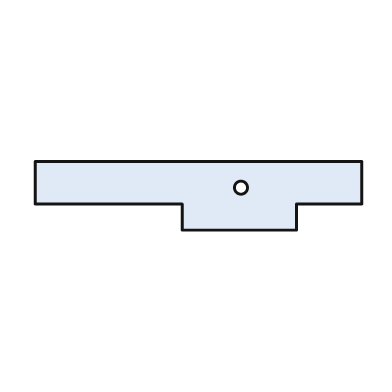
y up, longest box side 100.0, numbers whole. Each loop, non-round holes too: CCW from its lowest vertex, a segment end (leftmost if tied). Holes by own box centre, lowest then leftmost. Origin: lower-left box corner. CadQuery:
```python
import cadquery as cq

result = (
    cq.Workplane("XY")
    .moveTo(45.0, 0.0)
    .lineTo(80.0, 0.0)
    .lineTo(80.0, 8.0)
    .lineTo(100.0, 8.0)
    .lineTo(100.0, 21.0)
    .lineTo(0.0, 21.0)
    .lineTo(0.0, 8.0)
    .lineTo(45.0, 8.0)
    .close()
    .moveTo(63.0, 13.0)
    .circle(2.0)
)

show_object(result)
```